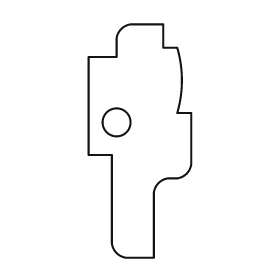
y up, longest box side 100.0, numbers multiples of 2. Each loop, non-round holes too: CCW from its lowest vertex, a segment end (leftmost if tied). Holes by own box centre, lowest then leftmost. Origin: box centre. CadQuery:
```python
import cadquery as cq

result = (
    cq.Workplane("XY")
    .moveTo(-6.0, -50.0)
    .lineTo(6.0, -50.0)
    .lineTo(6.0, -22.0)
    .threePointArc((8.0, -18.0), (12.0, -16.0))
    .lineTo(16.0, -16.0)
    .threePointArc((20.0, -14.0), (22.0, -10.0))
    .lineTo(22.0, 12.0)
    .lineTo(16.0, 12.0)
    .threePointArc((18.0, 26.0), (16.0, 40.0))
    .lineTo(10.0, 40.0)
    .lineTo(10.0, 50.0)
    .lineTo(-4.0, 50.0)
    .threePointArc((-8.0, 48.0), (-10.0, 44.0))
    .lineTo(-10.0, 36.0)
    .lineTo(-22.0, 36.0)
    .lineTo(-22.0, -6.0)
    .lineTo(-12.0, -6.0)
    .lineTo(-12.0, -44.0)
    .threePointArc((-10.0, -48.0), (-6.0, -50.0))
    .close()
    .moveTo(-10.0, 8.0)
    .circle(6.0)
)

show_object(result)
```